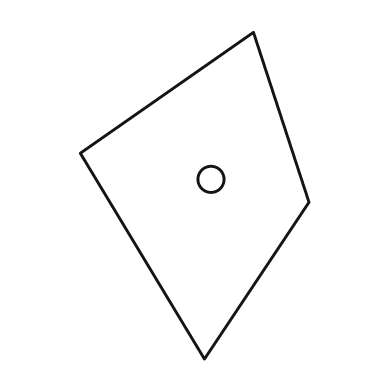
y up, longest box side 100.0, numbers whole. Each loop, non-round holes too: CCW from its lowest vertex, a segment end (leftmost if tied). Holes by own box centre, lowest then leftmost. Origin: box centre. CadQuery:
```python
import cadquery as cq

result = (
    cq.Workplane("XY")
    .moveTo(3.0, -50.0)
    .lineTo(35.0, -2.0)
    .lineTo(18.0, 50.0)
    .lineTo(-35.0, 13.0)
    .close()
    .moveTo(5.0, 5.0)
    .circle(4.0)
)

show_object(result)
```